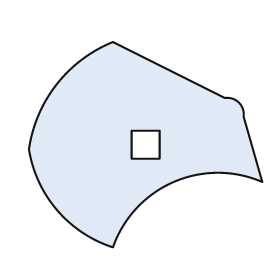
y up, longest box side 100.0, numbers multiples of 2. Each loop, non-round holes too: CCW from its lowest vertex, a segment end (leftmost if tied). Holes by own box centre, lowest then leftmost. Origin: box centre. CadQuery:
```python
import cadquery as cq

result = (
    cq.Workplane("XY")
    .moveTo(-14.0, -44.0)
    .threePointArc((12.0, -16.0), (50.0, -16.0))
    .lineTo(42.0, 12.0)
    .threePointArc((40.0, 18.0), (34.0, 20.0))
    .lineTo(-14.0, 44.0)
    .threePointArc((-38.0, 26.0), (-50.0, -2.0))
    .threePointArc((-38.0, -28.0), (-14.0, -44.0))
    .close()
    .moveTo(-6.0, -6.0)
    .lineTo(6.0, -6.0)
    .lineTo(6.0, 6.0)
    .lineTo(-6.0, 6.0)
    .close()
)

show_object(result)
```